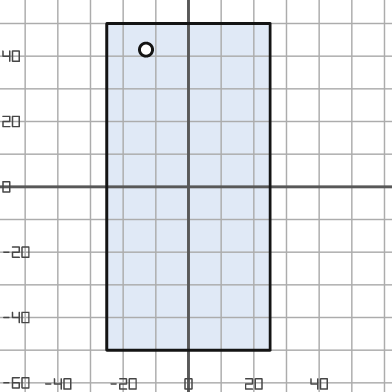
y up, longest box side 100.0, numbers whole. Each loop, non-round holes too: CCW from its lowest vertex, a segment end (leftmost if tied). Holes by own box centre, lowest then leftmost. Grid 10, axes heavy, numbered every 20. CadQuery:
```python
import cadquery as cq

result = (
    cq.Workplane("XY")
    .moveTo(-25.0, -50.0)
    .lineTo(25.0, -50.0)
    .lineTo(25.0, 50.0)
    .lineTo(-25.0, 50.0)
    .close()
    .moveTo(-13.0, 42.0)
    .circle(2.0)
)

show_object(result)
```